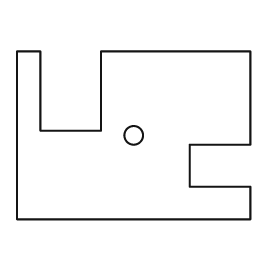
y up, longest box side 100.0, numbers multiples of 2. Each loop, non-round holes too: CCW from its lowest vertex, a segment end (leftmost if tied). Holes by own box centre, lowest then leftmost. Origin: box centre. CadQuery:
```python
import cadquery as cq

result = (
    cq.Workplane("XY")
    .moveTo(-50.0, -36.0)
    .lineTo(50.0, -36.0)
    .lineTo(50.0, -22.0)
    .lineTo(24.0, -22.0)
    .lineTo(24.0, -4.0)
    .lineTo(50.0, -4.0)
    .lineTo(50.0, 36.0)
    .lineTo(-14.0, 36.0)
    .lineTo(-14.0, 2.0)
    .lineTo(-40.0, 2.0)
    .lineTo(-40.0, 36.0)
    .lineTo(-50.0, 36.0)
    .close()
    .moveTo(0.0, 0.0)
    .circle(4.0)
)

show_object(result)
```